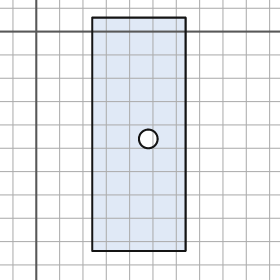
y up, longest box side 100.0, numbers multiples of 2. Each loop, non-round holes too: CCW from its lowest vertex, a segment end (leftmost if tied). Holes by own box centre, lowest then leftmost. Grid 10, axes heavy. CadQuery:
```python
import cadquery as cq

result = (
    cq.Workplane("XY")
    .moveTo(24.0, -94.0)
    .lineTo(64.0, -94.0)
    .lineTo(64.0, 6.0)
    .lineTo(24.0, 6.0)
    .close()
    .moveTo(48.0, -46.0)
    .circle(4.0)
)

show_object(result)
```